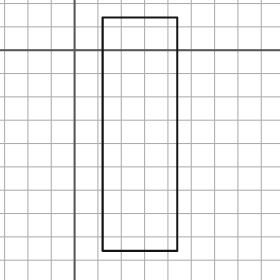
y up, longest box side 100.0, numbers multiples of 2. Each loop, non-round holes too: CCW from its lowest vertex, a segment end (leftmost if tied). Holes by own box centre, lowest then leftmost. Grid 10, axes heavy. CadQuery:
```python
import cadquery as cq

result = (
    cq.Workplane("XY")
    .moveTo(12.0, -86.0)
    .lineTo(44.0, -86.0)
    .lineTo(44.0, 14.0)
    .lineTo(12.0, 14.0)
    .close()
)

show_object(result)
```